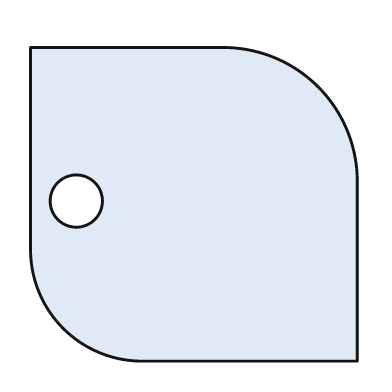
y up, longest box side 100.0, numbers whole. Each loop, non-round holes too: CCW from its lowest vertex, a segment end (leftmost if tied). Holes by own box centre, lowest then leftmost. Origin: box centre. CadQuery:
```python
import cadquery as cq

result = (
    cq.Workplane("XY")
    .moveTo(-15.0, -48.0)
    .lineTo(50.0, -48.0)
    .lineTo(50.0, 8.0)
    .threePointArc((38.0, 36.0), (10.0, 48.0))
    .lineTo(-50.0, 48.0)
    .lineTo(-50.0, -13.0)
    .threePointArc((-40.0, -38.0), (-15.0, -48.0))
    .close()
    .moveTo(-36.0, 1.0)
    .circle(8.0)
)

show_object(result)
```